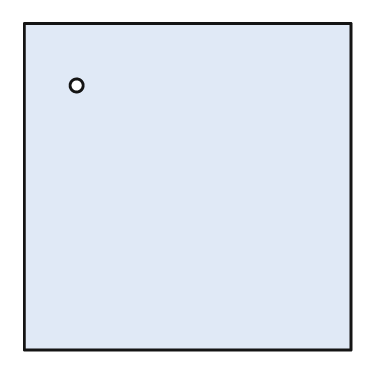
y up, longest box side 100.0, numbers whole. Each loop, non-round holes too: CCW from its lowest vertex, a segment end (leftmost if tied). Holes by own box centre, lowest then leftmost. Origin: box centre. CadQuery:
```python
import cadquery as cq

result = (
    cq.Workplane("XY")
    .moveTo(-50.0, -50.0)
    .lineTo(50.0, -50.0)
    .lineTo(50.0, 50.0)
    .lineTo(-50.0, 50.0)
    .close()
    .moveTo(-34.0, 31.0)
    .circle(2.0)
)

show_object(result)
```